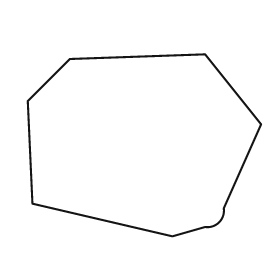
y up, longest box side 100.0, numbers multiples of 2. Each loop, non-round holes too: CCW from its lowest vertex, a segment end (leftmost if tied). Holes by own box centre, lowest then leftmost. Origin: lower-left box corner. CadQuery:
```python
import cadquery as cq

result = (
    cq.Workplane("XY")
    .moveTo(62.0, 0.0)
    .lineTo(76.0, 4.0)
    .threePointArc((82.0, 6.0), (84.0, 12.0))
    .lineTo(100.0, 48.0)
    .lineTo(76.0, 78.0)
    .lineTo(18.0, 76.0)
    .lineTo(0.0, 58.0)
    .lineTo(2.0, 14.0)
    .close()
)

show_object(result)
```